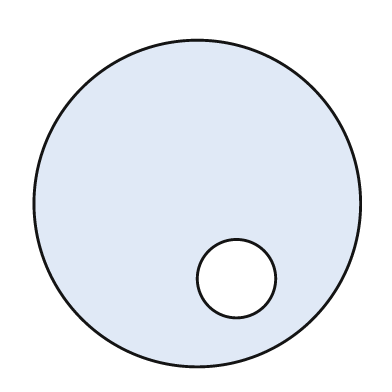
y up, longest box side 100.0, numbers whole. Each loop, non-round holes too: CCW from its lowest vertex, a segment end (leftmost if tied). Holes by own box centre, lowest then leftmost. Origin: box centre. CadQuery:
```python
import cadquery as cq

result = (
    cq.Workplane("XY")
    .moveTo(0.0, 0.0)
    .circle(50.0)
    .moveTo(12.0, -23.0)
    .circle(12.0)
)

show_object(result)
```